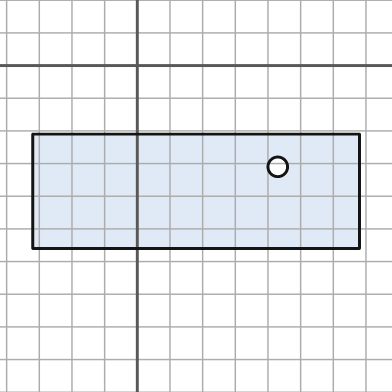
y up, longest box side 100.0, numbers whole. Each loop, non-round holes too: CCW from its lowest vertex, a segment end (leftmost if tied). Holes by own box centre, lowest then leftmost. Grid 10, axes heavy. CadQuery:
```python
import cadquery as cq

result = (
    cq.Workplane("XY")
    .moveTo(-32.0, -56.0)
    .lineTo(68.0, -56.0)
    .lineTo(68.0, -21.0)
    .lineTo(-32.0, -21.0)
    .close()
    .moveTo(43.0, -31.0)
    .circle(3.0)
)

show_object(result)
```